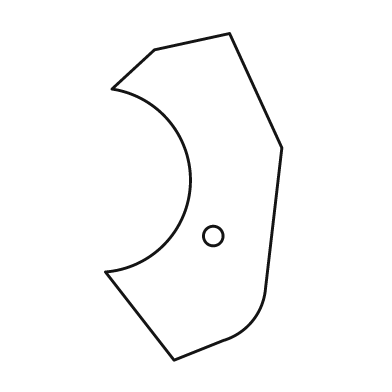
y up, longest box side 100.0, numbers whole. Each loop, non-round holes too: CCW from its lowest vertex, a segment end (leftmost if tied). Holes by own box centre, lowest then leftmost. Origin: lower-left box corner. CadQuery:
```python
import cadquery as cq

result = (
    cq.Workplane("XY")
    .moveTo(21.0, 0.0)
    .lineTo(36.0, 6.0)
    .threePointArc((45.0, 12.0), (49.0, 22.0))
    .lineTo(54.0, 65.0)
    .lineTo(38.0, 100.0)
    .lineTo(15.0, 95.0)
    .lineTo(2.0, 83.0)
    .threePointArc((26.0, 54.0), (0.0, 27.0))
    .close()
    .moveTo(33.0, 38.0)
    .circle(3.0)
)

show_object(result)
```